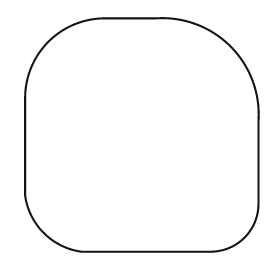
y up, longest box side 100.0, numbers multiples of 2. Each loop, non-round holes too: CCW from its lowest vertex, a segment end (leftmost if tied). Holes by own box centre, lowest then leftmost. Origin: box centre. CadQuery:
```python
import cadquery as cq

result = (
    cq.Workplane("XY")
    .moveTo(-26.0, -50.0)
    .lineTo(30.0, -50.0)
    .threePointArc((44.0, -44.0), (50.0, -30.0))
    .lineTo(50.0, 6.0)
    .threePointArc((38.0, 38.0), (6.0, 50.0))
    .lineTo(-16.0, 50.0)
    .threePointArc((-40.0, 40.0), (-50.0, 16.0))
    .lineTo(-50.0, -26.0)
    .threePointArc((-42.0, -42.0), (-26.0, -50.0))
    .close()
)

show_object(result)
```